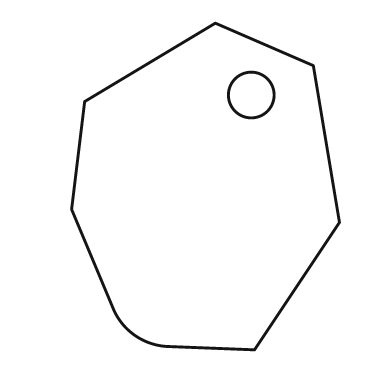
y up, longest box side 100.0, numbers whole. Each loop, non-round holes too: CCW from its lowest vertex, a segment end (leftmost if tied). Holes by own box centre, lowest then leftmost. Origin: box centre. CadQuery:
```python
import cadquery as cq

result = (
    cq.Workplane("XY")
    .moveTo(15.0, -50.0)
    .lineTo(41.0, -11.0)
    .lineTo(33.0, 37.0)
    .lineTo(3.0, 50.0)
    .lineTo(-37.0, 26.0)
    .lineTo(-41.0, -7.0)
    .lineTo(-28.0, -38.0)
    .threePointArc((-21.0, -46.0), (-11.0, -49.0))
    .close()
    .moveTo(14.0, 28.0)
    .circle(7.0)
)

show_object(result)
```